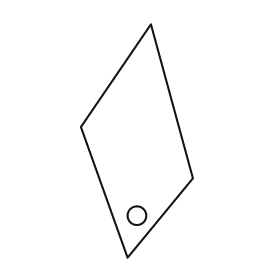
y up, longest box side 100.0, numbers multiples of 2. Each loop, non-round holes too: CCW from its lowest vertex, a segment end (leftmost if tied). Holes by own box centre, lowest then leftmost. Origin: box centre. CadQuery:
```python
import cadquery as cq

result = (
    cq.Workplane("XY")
    .moveTo(-4.0, -50.0)
    .lineTo(24.0, -16.0)
    .lineTo(6.0, 50.0)
    .lineTo(-24.0, 6.0)
    .close()
    .moveTo(0.0, -32.0)
    .circle(4.0)
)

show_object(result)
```